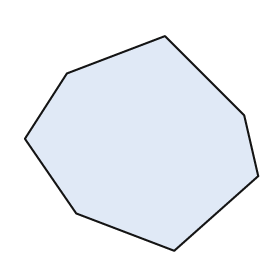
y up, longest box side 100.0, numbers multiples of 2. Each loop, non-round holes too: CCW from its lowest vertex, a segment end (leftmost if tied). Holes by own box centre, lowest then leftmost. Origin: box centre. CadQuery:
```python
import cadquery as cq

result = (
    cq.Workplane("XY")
    .moveTo(14.0, -46.0)
    .lineTo(50.0, -14.0)
    .lineTo(44.0, 12.0)
    .lineTo(10.0, 46.0)
    .lineTo(-32.0, 30.0)
    .lineTo(-50.0, 2.0)
    .lineTo(-28.0, -30.0)
    .close()
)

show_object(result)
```